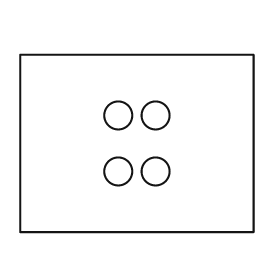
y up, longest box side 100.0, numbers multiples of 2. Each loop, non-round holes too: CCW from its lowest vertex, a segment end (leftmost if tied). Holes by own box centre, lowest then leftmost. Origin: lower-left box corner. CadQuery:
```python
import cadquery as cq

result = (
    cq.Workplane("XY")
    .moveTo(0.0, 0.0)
    .lineTo(100.0, 0.0)
    .lineTo(100.0, 76.0)
    .lineTo(0.0, 76.0)
    .close()
    .moveTo(42.0, 26.0)
    .circle(6.0)
    .moveTo(58.0, 26.0)
    .circle(6.0)
    .moveTo(42.0, 50.0)
    .circle(6.0)
    .moveTo(58.0, 50.0)
    .circle(6.0)
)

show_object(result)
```